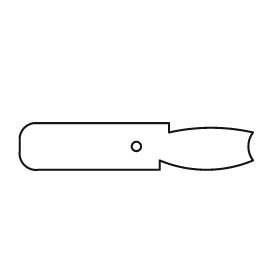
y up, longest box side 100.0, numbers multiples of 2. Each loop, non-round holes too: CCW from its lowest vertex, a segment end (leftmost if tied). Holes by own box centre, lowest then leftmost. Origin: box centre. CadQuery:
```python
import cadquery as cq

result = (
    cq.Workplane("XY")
    .moveTo(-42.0, -10.0)
    .lineTo(10.0, -10.0)
    .lineTo(10.0, -6.0)
    .threePointArc((30.0, -10.0), (50.0, -6.0))
    .threePointArc((48.0, 0.0), (50.0, 6.0))
    .threePointArc((32.0, 8.0), (14.0, 6.0))
    .lineTo(14.0, 10.0)
    .lineTo(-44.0, 10.0)
    .threePointArc((-48.0, 8.0), (-50.0, 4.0))
    .lineTo(-50.0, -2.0)
    .threePointArc((-48.0, -8.0), (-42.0, -10.0))
    .close()
    .moveTo(0.0, 0.0)
    .circle(2.0)
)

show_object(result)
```